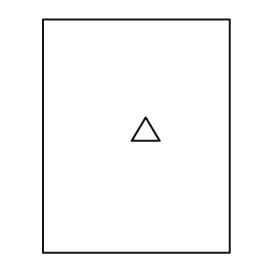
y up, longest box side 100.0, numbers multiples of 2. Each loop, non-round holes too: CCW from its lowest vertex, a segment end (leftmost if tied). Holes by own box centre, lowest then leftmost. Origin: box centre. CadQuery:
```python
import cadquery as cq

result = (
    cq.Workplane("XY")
    .moveTo(-40.0, -50.0)
    .lineTo(40.0, -50.0)
    .lineTo(40.0, 50.0)
    .lineTo(-40.0, 50.0)
    .close()
    .moveTo(-2.0, -2.0)
    .lineTo(10.0, -2.0)
    .lineTo(4.0, 8.0)
    .close()
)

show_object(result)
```